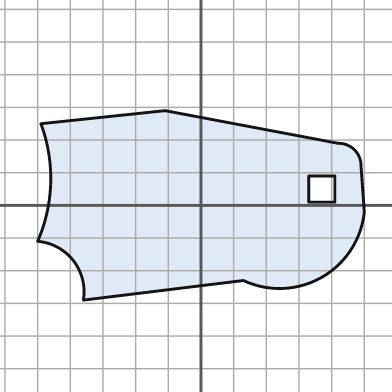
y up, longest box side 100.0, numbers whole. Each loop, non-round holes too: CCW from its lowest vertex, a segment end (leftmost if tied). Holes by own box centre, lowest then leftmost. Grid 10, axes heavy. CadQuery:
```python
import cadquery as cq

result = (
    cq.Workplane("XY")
    .moveTo(-36.0, -29.0)
    .lineTo(13.0, -23.0)
    .threePointArc((37.0, -22.0), (50.0, -2.0))
    .lineTo(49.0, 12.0)
    .threePointArc((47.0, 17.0), (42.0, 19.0))
    .lineTo(-11.0, 29.0)
    .lineTo(-49.0, 25.0)
    .threePointArc((-46.0, 7.0), (-50.0, -11.0))
    .threePointArc((-39.0, -17.0), (-36.0, -29.0))
    .close()
    .moveTo(33.0, 1.0)
    .lineTo(41.0, 1.0)
    .lineTo(41.0, 9.0)
    .lineTo(33.0, 9.0)
    .close()
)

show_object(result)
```